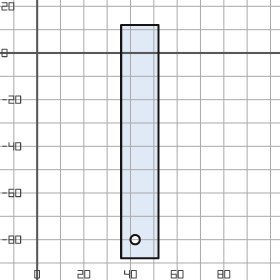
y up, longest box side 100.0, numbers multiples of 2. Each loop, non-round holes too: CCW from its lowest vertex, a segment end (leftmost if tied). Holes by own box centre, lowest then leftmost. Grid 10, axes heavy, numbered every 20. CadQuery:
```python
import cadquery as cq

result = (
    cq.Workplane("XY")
    .moveTo(36.0, -88.0)
    .lineTo(52.0, -88.0)
    .lineTo(52.0, 12.0)
    .lineTo(36.0, 12.0)
    .close()
    .moveTo(42.0, -80.0)
    .circle(2.0)
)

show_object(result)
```